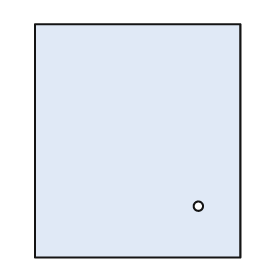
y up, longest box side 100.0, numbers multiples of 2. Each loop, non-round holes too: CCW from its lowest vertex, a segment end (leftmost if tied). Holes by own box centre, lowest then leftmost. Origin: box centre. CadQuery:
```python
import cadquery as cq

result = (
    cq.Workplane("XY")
    .moveTo(-44.0, -50.0)
    .lineTo(44.0, -50.0)
    .lineTo(44.0, 50.0)
    .lineTo(-44.0, 50.0)
    .close()
    .moveTo(26.0, -28.0)
    .circle(2.0)
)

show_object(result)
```